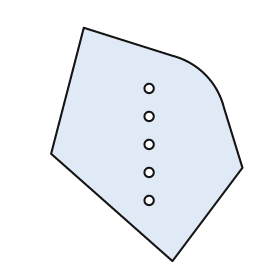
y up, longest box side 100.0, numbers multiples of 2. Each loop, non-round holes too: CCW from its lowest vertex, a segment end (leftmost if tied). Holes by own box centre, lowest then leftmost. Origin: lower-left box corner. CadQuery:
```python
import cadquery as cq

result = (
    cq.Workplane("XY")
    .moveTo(52.0, 0.0)
    .lineTo(82.0, 40.0)
    .lineTo(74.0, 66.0)
    .threePointArc((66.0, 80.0), (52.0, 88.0))
    .lineTo(14.0, 100.0)
    .lineTo(0.0, 46.0)
    .close()
    .moveTo(42.0, 26.0)
    .circle(2.0)
    .moveTo(42.0, 38.0)
    .circle(2.0)
    .moveTo(42.0, 50.0)
    .circle(2.0)
    .moveTo(42.0, 62.0)
    .circle(2.0)
    .moveTo(42.0, 74.0)
    .circle(2.0)
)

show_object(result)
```